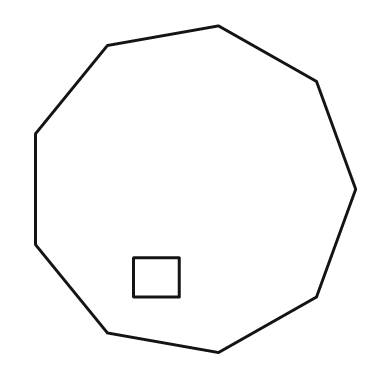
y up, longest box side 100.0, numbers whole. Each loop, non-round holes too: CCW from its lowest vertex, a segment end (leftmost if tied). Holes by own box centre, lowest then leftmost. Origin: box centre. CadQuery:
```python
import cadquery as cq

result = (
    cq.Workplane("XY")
    .moveTo(7.0, -50.0)
    .lineTo(37.0, -33.0)
    .lineTo(49.0, 0.0)
    .lineTo(37.0, 33.0)
    .lineTo(7.0, 50.0)
    .lineTo(-27.0, 44.0)
    .lineTo(-49.0, 17.0)
    .lineTo(-49.0, -17.0)
    .lineTo(-27.0, -44.0)
    .close()
    .moveTo(-19.0, -33.0)
    .lineTo(-5.0, -33.0)
    .lineTo(-5.0, -21.0)
    .lineTo(-19.0, -21.0)
    .close()
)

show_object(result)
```